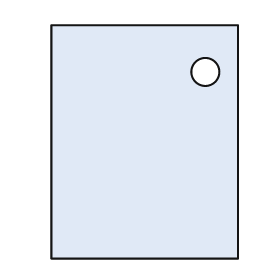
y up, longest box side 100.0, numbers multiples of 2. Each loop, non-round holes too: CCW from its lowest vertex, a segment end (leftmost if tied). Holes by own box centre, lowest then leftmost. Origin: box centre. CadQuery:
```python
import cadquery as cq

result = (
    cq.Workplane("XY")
    .moveTo(-40.0, -50.0)
    .lineTo(40.0, -50.0)
    .lineTo(40.0, 50.0)
    .lineTo(-40.0, 50.0)
    .close()
    .moveTo(26.0, 30.0)
    .circle(6.0)
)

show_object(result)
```